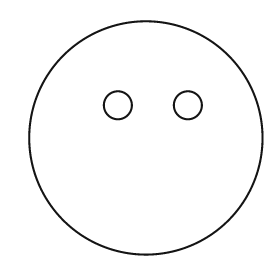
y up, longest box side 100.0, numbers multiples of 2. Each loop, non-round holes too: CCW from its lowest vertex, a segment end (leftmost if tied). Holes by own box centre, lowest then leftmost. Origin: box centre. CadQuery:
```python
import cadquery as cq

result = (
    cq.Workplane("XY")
    .moveTo(0.0, 0.0)
    .circle(50.0)
    .moveTo(-12.0, 14.0)
    .circle(6.0)
    .moveTo(18.0, 14.0)
    .circle(6.0)
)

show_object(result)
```